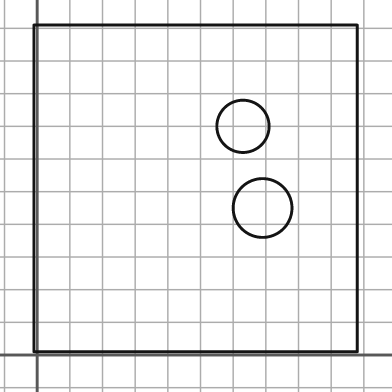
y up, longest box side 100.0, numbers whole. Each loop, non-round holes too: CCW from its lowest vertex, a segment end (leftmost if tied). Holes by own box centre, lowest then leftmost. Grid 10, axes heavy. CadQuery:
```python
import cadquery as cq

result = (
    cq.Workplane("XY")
    .moveTo(-1.0, 1.0)
    .lineTo(98.0, 1.0)
    .lineTo(98.0, 101.0)
    .lineTo(-1.0, 101.0)
    .close()
    .moveTo(69.0, 45.0)
    .circle(9.0)
    .moveTo(63.0, 70.0)
    .circle(8.0)
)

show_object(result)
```